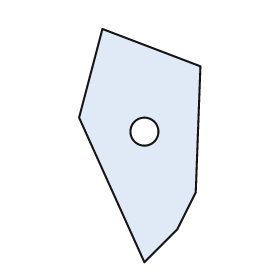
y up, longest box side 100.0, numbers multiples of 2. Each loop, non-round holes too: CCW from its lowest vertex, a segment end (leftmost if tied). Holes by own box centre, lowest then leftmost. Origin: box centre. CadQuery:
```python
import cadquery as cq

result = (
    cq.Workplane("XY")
    .moveTo(2.0, -50.0)
    .lineTo(16.0, -36.0)
    .lineTo(24.0, -20.0)
    .lineTo(26.0, 34.0)
    .lineTo(-16.0, 50.0)
    .lineTo(-26.0, 12.0)
    .close()
    .moveTo(2.0, 6.0)
    .circle(6.0)
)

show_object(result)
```